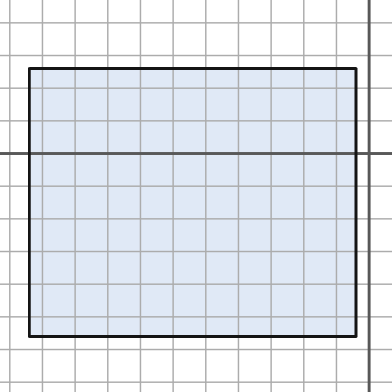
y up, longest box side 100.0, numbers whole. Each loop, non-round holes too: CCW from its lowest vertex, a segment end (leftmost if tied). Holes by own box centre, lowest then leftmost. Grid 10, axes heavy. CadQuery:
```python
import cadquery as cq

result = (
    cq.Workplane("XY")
    .moveTo(-104.0, -56.0)
    .lineTo(-4.0, -56.0)
    .lineTo(-4.0, 26.0)
    .lineTo(-104.0, 26.0)
    .close()
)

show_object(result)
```